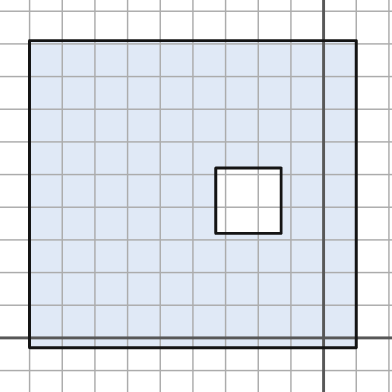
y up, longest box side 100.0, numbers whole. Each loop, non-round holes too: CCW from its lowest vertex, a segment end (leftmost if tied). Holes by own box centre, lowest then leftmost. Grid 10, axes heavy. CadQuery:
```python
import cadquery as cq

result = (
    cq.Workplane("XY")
    .moveTo(-90.0, -3.0)
    .lineTo(10.0, -3.0)
    .lineTo(10.0, 91.0)
    .lineTo(-90.0, 91.0)
    .close()
    .moveTo(-33.0, 32.0)
    .lineTo(-13.0, 32.0)
    .lineTo(-13.0, 52.0)
    .lineTo(-33.0, 52.0)
    .close()
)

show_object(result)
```